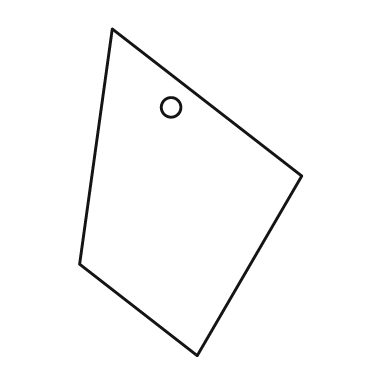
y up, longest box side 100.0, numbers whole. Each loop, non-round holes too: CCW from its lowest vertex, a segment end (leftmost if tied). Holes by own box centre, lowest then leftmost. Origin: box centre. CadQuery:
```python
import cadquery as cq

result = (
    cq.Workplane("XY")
    .moveTo(2.0, -50.0)
    .lineTo(34.0, 5.0)
    .lineTo(-24.0, 50.0)
    .lineTo(-34.0, -22.0)
    .close()
    .moveTo(-6.0, 26.0)
    .circle(3.0)
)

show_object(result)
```